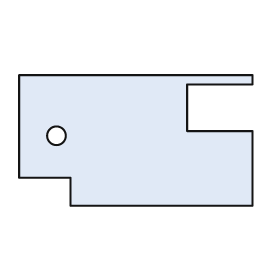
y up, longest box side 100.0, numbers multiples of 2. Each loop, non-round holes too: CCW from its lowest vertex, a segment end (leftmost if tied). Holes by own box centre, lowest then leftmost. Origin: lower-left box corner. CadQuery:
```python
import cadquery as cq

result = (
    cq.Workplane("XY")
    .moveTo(22.0, 0.0)
    .lineTo(100.0, 0.0)
    .lineTo(100.0, 32.0)
    .lineTo(72.0, 32.0)
    .lineTo(72.0, 52.0)
    .lineTo(100.0, 52.0)
    .lineTo(100.0, 56.0)
    .lineTo(0.0, 56.0)
    .lineTo(0.0, 12.0)
    .lineTo(22.0, 12.0)
    .close()
    .moveTo(16.0, 30.0)
    .circle(4.0)
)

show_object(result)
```